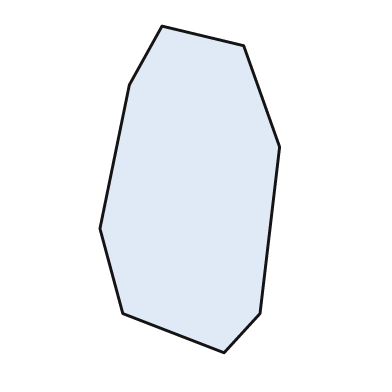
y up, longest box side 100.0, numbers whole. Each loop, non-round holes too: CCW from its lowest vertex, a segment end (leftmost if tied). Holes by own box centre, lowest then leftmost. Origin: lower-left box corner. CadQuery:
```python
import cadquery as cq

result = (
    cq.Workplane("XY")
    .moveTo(38.0, 0.0)
    .lineTo(49.0, 12.0)
    .lineTo(55.0, 63.0)
    .lineTo(44.0, 94.0)
    .lineTo(19.0, 100.0)
    .lineTo(9.0, 82.0)
    .lineTo(0.0, 38.0)
    .lineTo(7.0, 12.0)
    .close()
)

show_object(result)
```